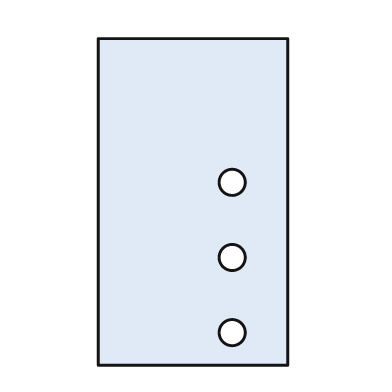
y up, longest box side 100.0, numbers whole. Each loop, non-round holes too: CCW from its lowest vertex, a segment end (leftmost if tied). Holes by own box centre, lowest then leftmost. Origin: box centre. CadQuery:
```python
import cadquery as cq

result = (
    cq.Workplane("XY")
    .moveTo(-29.0, -50.0)
    .lineTo(29.0, -50.0)
    .lineTo(29.0, 50.0)
    .lineTo(-29.0, 50.0)
    .close()
    .moveTo(12.0, -40.0)
    .circle(4.0)
    .moveTo(12.0, -17.0)
    .circle(4.0)
    .moveTo(12.0, 6.0)
    .circle(4.0)
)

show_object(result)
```